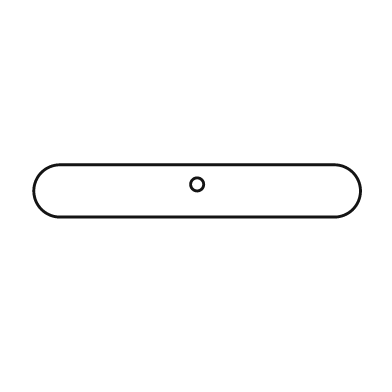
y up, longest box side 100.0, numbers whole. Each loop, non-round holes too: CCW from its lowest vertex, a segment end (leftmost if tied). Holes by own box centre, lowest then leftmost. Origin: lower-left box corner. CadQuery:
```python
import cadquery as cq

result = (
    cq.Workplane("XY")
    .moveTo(8.0, 0.0)
    .lineTo(92.0, 0.0)
    .threePointArc((100.0, 8.0), (92.0, 16.0))
    .lineTo(8.0, 16.0)
    .threePointArc((0.0, 8.0), (8.0, 0.0))
    .close()
    .moveTo(50.0, 10.0)
    .circle(2.0)
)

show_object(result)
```